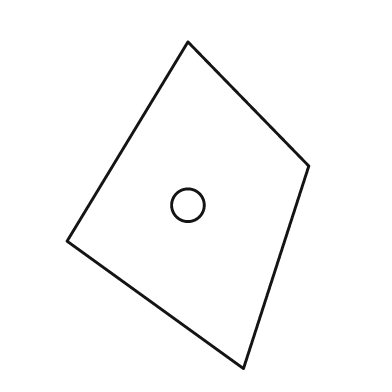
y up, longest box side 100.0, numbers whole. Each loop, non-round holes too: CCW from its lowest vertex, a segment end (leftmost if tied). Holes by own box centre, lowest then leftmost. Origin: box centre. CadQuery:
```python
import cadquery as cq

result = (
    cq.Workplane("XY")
    .moveTo(17.0, -50.0)
    .lineTo(37.0, 12.0)
    .lineTo(0.0, 50.0)
    .lineTo(-37.0, -11.0)
    .close()
    .moveTo(0.0, 0.0)
    .circle(5.0)
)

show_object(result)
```